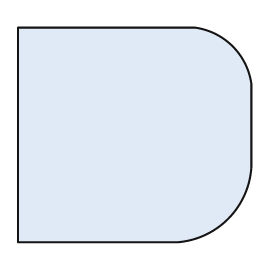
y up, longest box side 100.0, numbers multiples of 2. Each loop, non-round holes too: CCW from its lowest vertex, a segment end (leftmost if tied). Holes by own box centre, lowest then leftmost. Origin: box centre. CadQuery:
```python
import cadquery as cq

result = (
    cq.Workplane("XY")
    .moveTo(-50.0, -46.0)
    .lineTo(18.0, -46.0)
    .threePointArc((40.0, -36.0), (50.0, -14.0))
    .lineTo(50.0, 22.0)
    .threePointArc((42.0, 38.0), (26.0, 46.0))
    .lineTo(-50.0, 46.0)
    .close()
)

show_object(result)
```